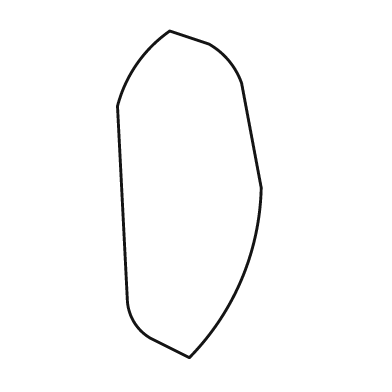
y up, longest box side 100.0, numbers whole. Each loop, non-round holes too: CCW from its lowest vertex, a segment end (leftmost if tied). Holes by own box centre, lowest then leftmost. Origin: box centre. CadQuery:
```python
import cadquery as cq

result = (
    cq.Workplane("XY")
    .moveTo(0.0, -50.0)
    .threePointArc((16.0, -26.0), (22.0, 2.0))
    .lineTo(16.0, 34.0)
    .threePointArc((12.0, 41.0), (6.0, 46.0))
    .lineTo(-6.0, 50.0)
    .threePointArc((-16.0, 40.0), (-22.0, 27.0))
    .lineTo(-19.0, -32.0)
    .threePointArc((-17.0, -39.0), (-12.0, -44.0))
    .close()
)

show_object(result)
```